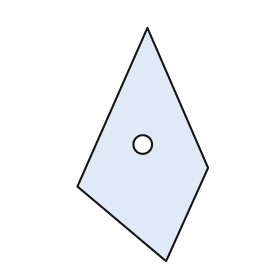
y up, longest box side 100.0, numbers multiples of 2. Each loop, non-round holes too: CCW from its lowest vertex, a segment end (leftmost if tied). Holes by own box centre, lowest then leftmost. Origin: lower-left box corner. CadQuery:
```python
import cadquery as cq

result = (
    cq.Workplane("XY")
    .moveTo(38.0, 0.0)
    .lineTo(56.0, 40.0)
    .lineTo(30.0, 100.0)
    .lineTo(0.0, 32.0)
    .close()
    .moveTo(28.0, 50.0)
    .circle(4.0)
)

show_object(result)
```